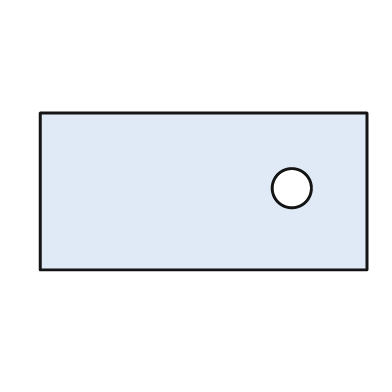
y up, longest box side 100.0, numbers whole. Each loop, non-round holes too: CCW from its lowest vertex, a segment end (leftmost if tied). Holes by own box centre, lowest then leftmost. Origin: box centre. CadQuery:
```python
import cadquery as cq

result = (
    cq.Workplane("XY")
    .moveTo(-50.0, -24.0)
    .lineTo(50.0, -24.0)
    .lineTo(50.0, 24.0)
    .lineTo(-50.0, 24.0)
    .close()
    .moveTo(27.0, 1.0)
    .circle(6.0)
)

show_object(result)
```